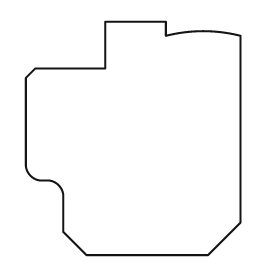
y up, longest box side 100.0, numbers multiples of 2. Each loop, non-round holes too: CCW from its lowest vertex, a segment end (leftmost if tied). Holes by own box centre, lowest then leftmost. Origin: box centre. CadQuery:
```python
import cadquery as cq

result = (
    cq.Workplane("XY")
    .moveTo(-20.0, -50.0)
    .lineTo(32.0, -50.0)
    .lineTo(46.0, -36.0)
    .lineTo(46.0, 44.0)
    .threePointArc((30.0, 46.0), (14.0, 44.0))
    .lineTo(14.0, 50.0)
    .lineTo(-12.0, 50.0)
    .lineTo(-12.0, 30.0)
    .lineTo(-42.0, 30.0)
    .lineTo(-46.0, 26.0)
    .lineTo(-46.0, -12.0)
    .threePointArc((-44.0, -16.0), (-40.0, -18.0))
    .lineTo(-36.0, -18.0)
    .threePointArc((-32.0, -20.0), (-30.0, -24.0))
    .lineTo(-30.0, -40.0)
    .close()
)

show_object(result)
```